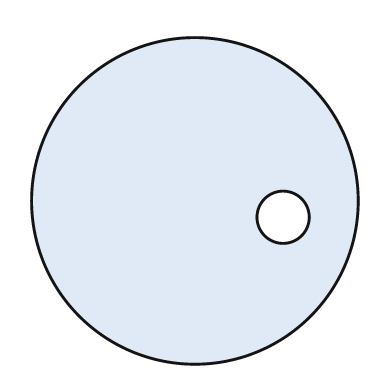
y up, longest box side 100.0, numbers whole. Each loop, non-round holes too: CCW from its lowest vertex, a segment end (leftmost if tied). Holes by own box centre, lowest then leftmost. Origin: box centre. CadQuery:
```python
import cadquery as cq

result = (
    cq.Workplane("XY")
    .moveTo(0.0, 0.0)
    .circle(50.0)
    .moveTo(27.0, -5.0)
    .circle(8.0)
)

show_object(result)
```